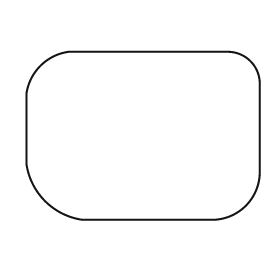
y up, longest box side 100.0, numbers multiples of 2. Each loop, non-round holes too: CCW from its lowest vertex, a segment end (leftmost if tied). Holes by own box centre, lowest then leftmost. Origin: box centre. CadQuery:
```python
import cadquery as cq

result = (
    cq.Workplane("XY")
    .moveTo(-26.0, -36.0)
    .lineTo(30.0, -36.0)
    .threePointArc((44.0, -30.0), (50.0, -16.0))
    .lineTo(50.0, 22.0)
    .threePointArc((46.0, 32.0), (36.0, 36.0))
    .lineTo(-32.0, 36.0)
    .threePointArc((-44.0, 30.0), (-50.0, 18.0))
    .lineTo(-50.0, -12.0)
    .threePointArc((-42.0, -28.0), (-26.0, -36.0))
    .close()
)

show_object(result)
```